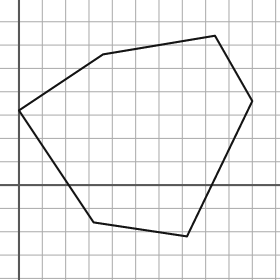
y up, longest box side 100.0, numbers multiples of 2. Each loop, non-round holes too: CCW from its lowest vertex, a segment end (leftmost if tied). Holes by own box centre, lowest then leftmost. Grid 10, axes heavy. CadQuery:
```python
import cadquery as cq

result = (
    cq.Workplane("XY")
    .moveTo(72.0, -22.0)
    .lineTo(100.0, 36.0)
    .lineTo(84.0, 64.0)
    .lineTo(36.0, 56.0)
    .lineTo(0.0, 32.0)
    .lineTo(32.0, -16.0)
    .close()
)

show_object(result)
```